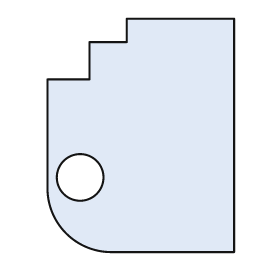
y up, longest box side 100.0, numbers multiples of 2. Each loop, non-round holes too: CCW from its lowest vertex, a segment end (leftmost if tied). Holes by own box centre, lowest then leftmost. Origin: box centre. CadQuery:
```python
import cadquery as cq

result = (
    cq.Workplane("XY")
    .moveTo(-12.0, -50.0)
    .lineTo(40.0, -50.0)
    .lineTo(40.0, 50.0)
    .lineTo(-6.0, 50.0)
    .lineTo(-6.0, 40.0)
    .lineTo(-22.0, 40.0)
    .lineTo(-22.0, 24.0)
    .lineTo(-40.0, 24.0)
    .lineTo(-40.0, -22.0)
    .threePointArc((-32.0, -42.0), (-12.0, -50.0))
    .close()
    .moveTo(-26.0, -18.0)
    .circle(10.0)
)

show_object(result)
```